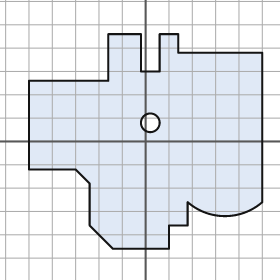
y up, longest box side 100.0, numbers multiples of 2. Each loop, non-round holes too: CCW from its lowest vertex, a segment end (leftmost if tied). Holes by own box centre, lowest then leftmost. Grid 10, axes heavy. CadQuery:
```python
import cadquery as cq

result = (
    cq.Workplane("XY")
    .moveTo(-14.0, -46.0)
    .lineTo(10.0, -46.0)
    .lineTo(10.0, -36.0)
    .lineTo(18.0, -36.0)
    .lineTo(18.0, -26.0)
    .threePointArc((34.0, -32.0), (50.0, -26.0))
    .lineTo(50.0, 38.0)
    .lineTo(14.0, 38.0)
    .lineTo(14.0, 46.0)
    .lineTo(6.0, 46.0)
    .lineTo(6.0, 30.0)
    .lineTo(-2.0, 30.0)
    .lineTo(-2.0, 46.0)
    .lineTo(-16.0, 46.0)
    .lineTo(-16.0, 26.0)
    .lineTo(-50.0, 26.0)
    .lineTo(-50.0, -12.0)
    .lineTo(-30.0, -12.0)
    .lineTo(-24.0, -18.0)
    .lineTo(-24.0, -36.0)
    .close()
    .moveTo(2.0, 8.0)
    .circle(4.0)
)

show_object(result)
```